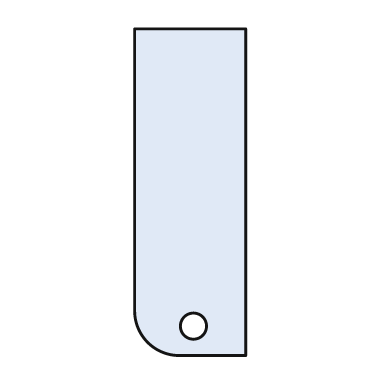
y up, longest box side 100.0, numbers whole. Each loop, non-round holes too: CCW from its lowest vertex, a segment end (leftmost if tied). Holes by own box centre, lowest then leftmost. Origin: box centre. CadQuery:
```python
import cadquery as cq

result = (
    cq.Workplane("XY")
    .moveTo(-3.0, -50.0)
    .lineTo(17.0, -50.0)
    .lineTo(17.0, 50.0)
    .lineTo(-17.0, 50.0)
    .lineTo(-17.0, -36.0)
    .threePointArc((-13.0, -46.0), (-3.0, -50.0))
    .close()
    .moveTo(1.0, -41.0)
    .circle(4.0)
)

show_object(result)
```